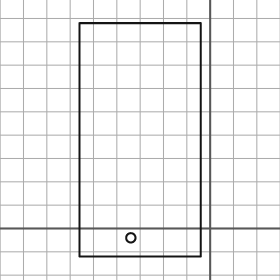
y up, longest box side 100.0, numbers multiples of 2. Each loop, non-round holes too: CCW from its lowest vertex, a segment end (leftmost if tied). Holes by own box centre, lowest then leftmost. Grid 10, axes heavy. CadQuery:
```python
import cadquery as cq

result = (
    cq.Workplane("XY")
    .moveTo(-56.0, -12.0)
    .lineTo(-4.0, -12.0)
    .lineTo(-4.0, 88.0)
    .lineTo(-56.0, 88.0)
    .close()
    .moveTo(-34.0, -4.0)
    .circle(2.0)
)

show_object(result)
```